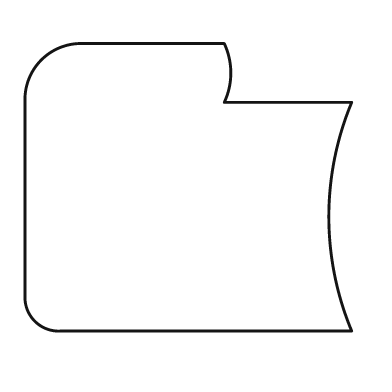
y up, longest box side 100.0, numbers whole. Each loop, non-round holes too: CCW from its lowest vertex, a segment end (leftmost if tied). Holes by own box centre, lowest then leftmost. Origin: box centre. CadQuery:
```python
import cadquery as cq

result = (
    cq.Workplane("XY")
    .moveTo(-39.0, -44.0)
    .lineTo(50.0, -44.0)
    .threePointArc((43.0, -9.0), (50.0, 26.0))
    .lineTo(11.0, 26.0)
    .threePointArc((13.0, 35.0), (11.0, 44.0))
    .lineTo(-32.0, 44.0)
    .threePointArc((-45.0, 39.0), (-50.0, 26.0))
    .lineTo(-50.0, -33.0)
    .threePointArc((-47.0, -41.0), (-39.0, -44.0))
    .close()
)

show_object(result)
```